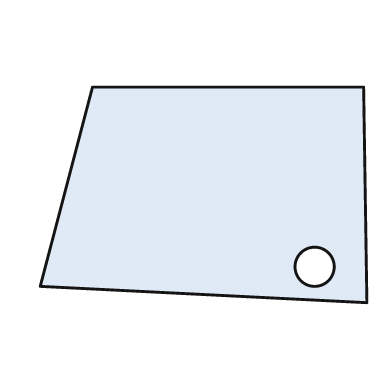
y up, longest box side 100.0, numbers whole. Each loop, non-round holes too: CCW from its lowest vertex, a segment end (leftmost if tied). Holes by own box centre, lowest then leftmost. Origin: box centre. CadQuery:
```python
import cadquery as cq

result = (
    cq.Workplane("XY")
    .moveTo(50.0, -33.0)
    .lineTo(49.0, 33.0)
    .lineTo(-34.0, 33.0)
    .lineTo(-50.0, -28.0)
    .close()
    .moveTo(34.0, -22.0)
    .circle(6.0)
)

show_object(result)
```